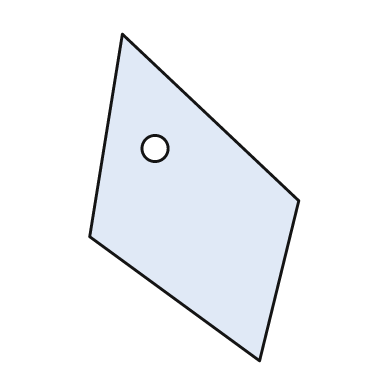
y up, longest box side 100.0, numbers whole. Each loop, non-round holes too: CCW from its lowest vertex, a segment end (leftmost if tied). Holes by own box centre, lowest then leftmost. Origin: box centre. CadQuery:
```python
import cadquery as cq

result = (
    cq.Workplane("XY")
    .moveTo(20.0, -50.0)
    .lineTo(32.0, -1.0)
    .lineTo(-22.0, 50.0)
    .lineTo(-32.0, -12.0)
    .close()
    .moveTo(-12.0, 15.0)
    .circle(4.0)
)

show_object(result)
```